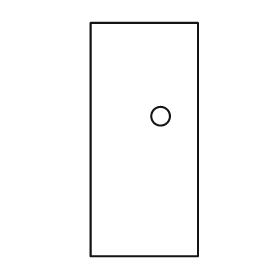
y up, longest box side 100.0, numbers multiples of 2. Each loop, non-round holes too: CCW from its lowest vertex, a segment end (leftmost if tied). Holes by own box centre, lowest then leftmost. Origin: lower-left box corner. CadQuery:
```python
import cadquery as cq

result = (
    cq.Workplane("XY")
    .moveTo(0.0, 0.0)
    .lineTo(46.0, 0.0)
    .lineTo(46.0, 100.0)
    .lineTo(0.0, 100.0)
    .close()
    .moveTo(30.0, 60.0)
    .circle(4.0)
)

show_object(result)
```